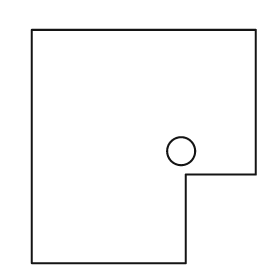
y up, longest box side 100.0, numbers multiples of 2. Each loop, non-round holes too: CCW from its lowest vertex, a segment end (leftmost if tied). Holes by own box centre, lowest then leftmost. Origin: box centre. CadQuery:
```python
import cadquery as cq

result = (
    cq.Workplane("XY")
    .moveTo(-48.0, -50.0)
    .lineTo(18.0, -50.0)
    .lineTo(18.0, -12.0)
    .lineTo(48.0, -12.0)
    .lineTo(48.0, 50.0)
    .lineTo(-48.0, 50.0)
    .close()
    .moveTo(16.0, -2.0)
    .circle(6.0)
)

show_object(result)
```